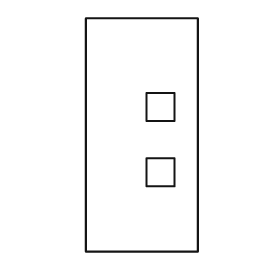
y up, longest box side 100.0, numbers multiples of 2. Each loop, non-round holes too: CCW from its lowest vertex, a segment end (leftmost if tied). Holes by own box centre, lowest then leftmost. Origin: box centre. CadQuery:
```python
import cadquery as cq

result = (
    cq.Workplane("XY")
    .moveTo(-24.0, -50.0)
    .lineTo(24.0, -50.0)
    .lineTo(24.0, 50.0)
    .lineTo(-24.0, 50.0)
    .close()
    .moveTo(2.0, -22.0)
    .lineTo(14.0, -22.0)
    .lineTo(14.0, -10.0)
    .lineTo(2.0, -10.0)
    .close()
    .moveTo(2.0, 6.0)
    .lineTo(14.0, 6.0)
    .lineTo(14.0, 18.0)
    .lineTo(2.0, 18.0)
    .close()
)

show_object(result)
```